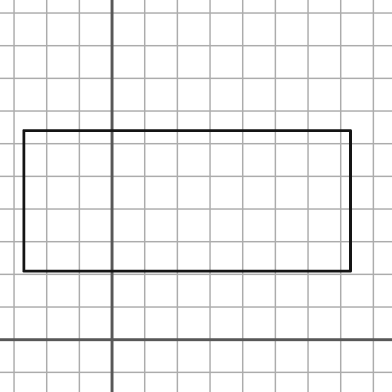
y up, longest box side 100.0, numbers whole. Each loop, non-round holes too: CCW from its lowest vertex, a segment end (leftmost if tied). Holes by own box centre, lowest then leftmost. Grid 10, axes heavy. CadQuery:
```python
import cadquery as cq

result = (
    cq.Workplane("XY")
    .moveTo(-27.0, 21.0)
    .lineTo(73.0, 21.0)
    .lineTo(73.0, 64.0)
    .lineTo(-27.0, 64.0)
    .close()
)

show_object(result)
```